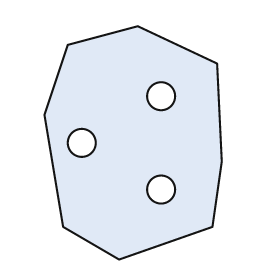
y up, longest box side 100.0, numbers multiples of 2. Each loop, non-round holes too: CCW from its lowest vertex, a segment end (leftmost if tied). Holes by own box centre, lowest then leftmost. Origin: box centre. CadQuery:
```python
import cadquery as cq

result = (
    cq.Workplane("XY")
    .moveTo(-6.0, -50.0)
    .lineTo(34.0, -36.0)
    .lineTo(38.0, -8.0)
    .lineTo(36.0, 34.0)
    .lineTo(2.0, 50.0)
    .lineTo(-28.0, 42.0)
    .lineTo(-38.0, 12.0)
    .lineTo(-30.0, -36.0)
    .close()
    .moveTo(12.0, -20.0)
    .circle(6.0)
    .moveTo(-22.0, 0.0)
    .circle(6.0)
    .moveTo(12.0, 20.0)
    .circle(6.0)
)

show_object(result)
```